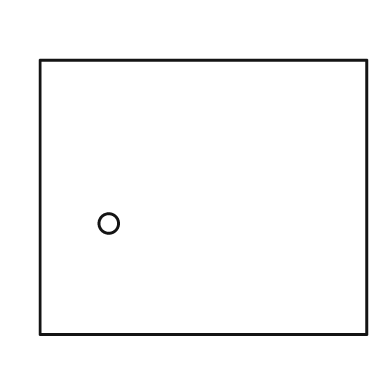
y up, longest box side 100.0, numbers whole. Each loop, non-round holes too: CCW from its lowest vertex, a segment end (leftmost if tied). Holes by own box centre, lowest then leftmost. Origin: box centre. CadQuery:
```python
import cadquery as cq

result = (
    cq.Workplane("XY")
    .moveTo(-50.0, -42.0)
    .lineTo(50.0, -42.0)
    .lineTo(50.0, 42.0)
    .lineTo(-50.0, 42.0)
    .close()
    .moveTo(-29.0, -8.0)
    .circle(3.0)
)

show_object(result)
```